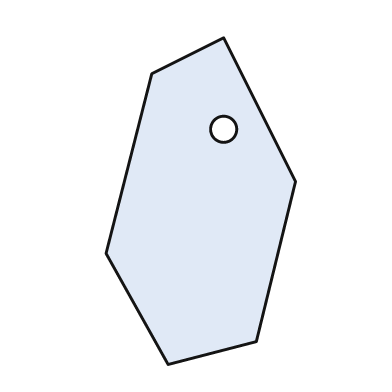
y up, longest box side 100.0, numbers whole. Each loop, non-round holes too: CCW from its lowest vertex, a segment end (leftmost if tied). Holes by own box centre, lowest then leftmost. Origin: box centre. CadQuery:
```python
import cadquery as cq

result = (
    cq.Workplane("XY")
    .moveTo(-10.0, -50.0)
    .lineTo(17.0, -43.0)
    .lineTo(29.0, 6.0)
    .lineTo(7.0, 50.0)
    .lineTo(-15.0, 39.0)
    .lineTo(-29.0, -16.0)
    .close()
    .moveTo(7.0, 22.0)
    .circle(4.0)
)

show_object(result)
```